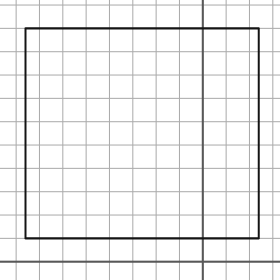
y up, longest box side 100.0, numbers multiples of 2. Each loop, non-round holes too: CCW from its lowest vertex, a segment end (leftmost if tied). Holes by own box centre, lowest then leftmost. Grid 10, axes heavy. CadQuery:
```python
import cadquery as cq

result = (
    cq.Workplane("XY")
    .moveTo(-76.0, 10.0)
    .lineTo(24.0, 10.0)
    .lineTo(24.0, 100.0)
    .lineTo(-76.0, 100.0)
    .close()
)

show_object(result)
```